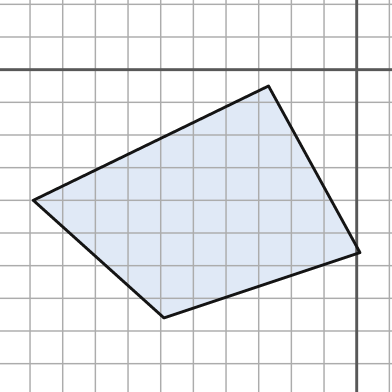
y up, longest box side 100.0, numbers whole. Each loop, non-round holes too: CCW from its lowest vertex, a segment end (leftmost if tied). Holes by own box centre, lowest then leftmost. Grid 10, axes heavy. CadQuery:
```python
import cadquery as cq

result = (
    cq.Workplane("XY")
    .moveTo(-59.0, -76.0)
    .lineTo(1.0, -56.0)
    .lineTo(-27.0, -5.0)
    .lineTo(-99.0, -40.0)
    .close()
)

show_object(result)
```